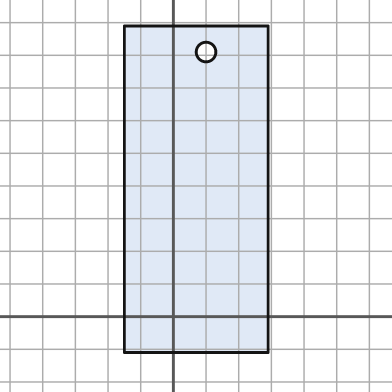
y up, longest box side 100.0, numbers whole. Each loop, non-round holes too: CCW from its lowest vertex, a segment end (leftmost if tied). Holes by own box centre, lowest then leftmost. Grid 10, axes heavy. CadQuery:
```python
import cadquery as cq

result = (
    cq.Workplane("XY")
    .moveTo(-15.0, -11.0)
    .lineTo(29.0, -11.0)
    .lineTo(29.0, 89.0)
    .lineTo(-15.0, 89.0)
    .close()
    .moveTo(10.0, 81.0)
    .circle(3.0)
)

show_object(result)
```